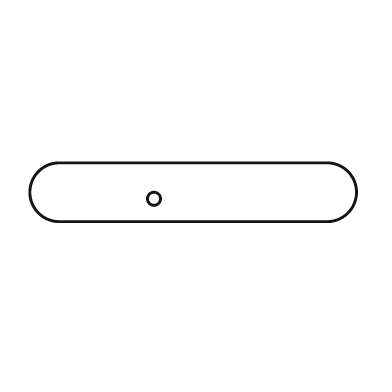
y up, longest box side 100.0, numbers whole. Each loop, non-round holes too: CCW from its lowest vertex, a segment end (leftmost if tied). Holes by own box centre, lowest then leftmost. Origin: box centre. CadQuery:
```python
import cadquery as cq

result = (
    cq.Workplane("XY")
    .moveTo(-41.0, -9.0)
    .lineTo(41.0, -9.0)
    .threePointArc((50.0, 0.0), (41.0, 9.0))
    .lineTo(-41.0, 9.0)
    .threePointArc((-50.0, 0.0), (-41.0, -9.0))
    .close()
    .moveTo(-12.0, -2.0)
    .circle(2.0)
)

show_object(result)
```